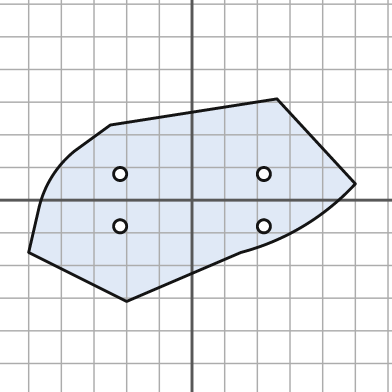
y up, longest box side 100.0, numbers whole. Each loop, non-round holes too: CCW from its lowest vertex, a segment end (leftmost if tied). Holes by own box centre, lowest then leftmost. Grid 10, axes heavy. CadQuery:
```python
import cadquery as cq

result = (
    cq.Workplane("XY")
    .moveTo(-20.0, -31.0)
    .lineTo(15.0, -16.0)
    .threePointArc((34.0, -8.0), (50.0, 5.0))
    .lineTo(26.0, 31.0)
    .lineTo(-25.0, 23.0)
    .lineTo(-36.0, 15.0)
    .threePointArc((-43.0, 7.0), (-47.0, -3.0))
    .lineTo(-50.0, -16.0)
    .close()
    .moveTo(-22.0, -8.0)
    .circle(2.0)
    .moveTo(22.0, -8.0)
    .circle(2.0)
    .moveTo(-22.0, 8.0)
    .circle(2.0)
    .moveTo(22.0, 8.0)
    .circle(2.0)
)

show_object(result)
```